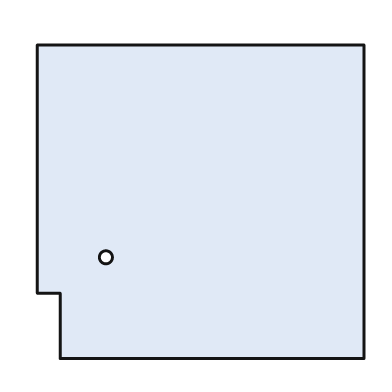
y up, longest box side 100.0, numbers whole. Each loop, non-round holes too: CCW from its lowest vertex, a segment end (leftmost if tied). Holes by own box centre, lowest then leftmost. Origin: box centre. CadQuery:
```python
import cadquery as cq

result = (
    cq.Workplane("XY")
    .moveTo(-43.0, -48.0)
    .lineTo(50.0, -48.0)
    .lineTo(50.0, 48.0)
    .lineTo(-50.0, 48.0)
    .lineTo(-50.0, -28.0)
    .lineTo(-43.0, -28.0)
    .close()
    .moveTo(-29.0, -17.0)
    .circle(2.0)
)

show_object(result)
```